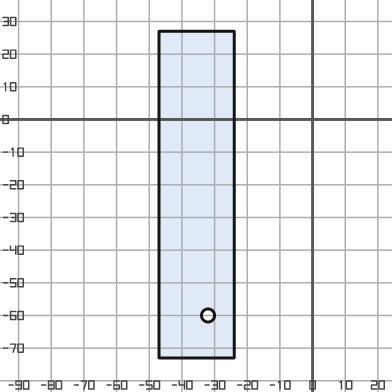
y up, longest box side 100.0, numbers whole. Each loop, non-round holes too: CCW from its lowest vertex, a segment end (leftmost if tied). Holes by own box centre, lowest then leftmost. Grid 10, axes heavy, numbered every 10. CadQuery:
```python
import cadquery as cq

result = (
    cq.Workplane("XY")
    .moveTo(-47.0, -73.0)
    .lineTo(-24.0, -73.0)
    .lineTo(-24.0, 27.0)
    .lineTo(-47.0, 27.0)
    .close()
    .moveTo(-32.0, -60.0)
    .circle(2.0)
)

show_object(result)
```